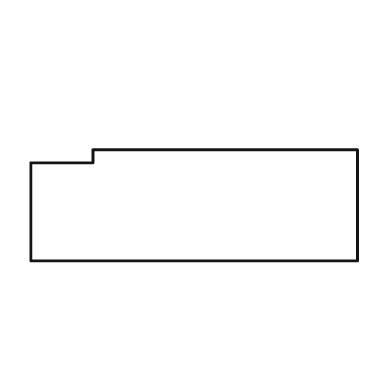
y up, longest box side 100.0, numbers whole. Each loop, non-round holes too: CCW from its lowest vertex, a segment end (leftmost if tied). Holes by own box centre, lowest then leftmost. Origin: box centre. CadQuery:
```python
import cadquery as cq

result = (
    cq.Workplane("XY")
    .moveTo(-50.0, -17.0)
    .lineTo(50.0, -17.0)
    .lineTo(50.0, 17.0)
    .lineTo(-31.0, 17.0)
    .lineTo(-31.0, 13.0)
    .lineTo(-50.0, 13.0)
    .close()
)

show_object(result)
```